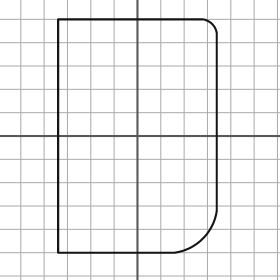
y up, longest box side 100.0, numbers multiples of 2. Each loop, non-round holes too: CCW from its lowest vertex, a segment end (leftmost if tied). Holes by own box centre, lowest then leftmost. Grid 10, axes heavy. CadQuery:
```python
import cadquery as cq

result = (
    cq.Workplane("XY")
    .moveTo(-34.0, -50.0)
    .lineTo(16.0, -50.0)
    .threePointArc((28.0, -44.0), (34.0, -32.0))
    .lineTo(34.0, 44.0)
    .threePointArc((32.0, 48.0), (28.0, 50.0))
    .lineTo(-34.0, 50.0)
    .close()
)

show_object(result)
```